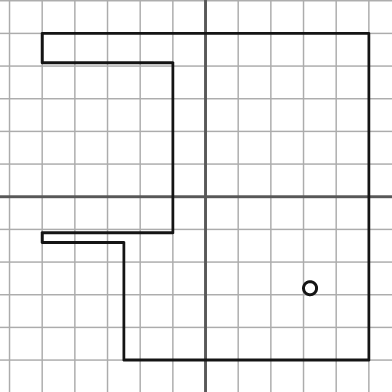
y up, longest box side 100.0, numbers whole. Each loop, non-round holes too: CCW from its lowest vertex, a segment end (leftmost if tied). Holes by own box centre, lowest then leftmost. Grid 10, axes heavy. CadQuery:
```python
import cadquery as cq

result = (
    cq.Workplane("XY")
    .moveTo(-25.0, -50.0)
    .lineTo(50.0, -50.0)
    .lineTo(50.0, 50.0)
    .lineTo(-50.0, 50.0)
    .lineTo(-50.0, 41.0)
    .lineTo(-10.0, 41.0)
    .lineTo(-10.0, -11.0)
    .lineTo(-50.0, -11.0)
    .lineTo(-50.0, -14.0)
    .lineTo(-25.0, -14.0)
    .close()
    .moveTo(32.0, -28.0)
    .circle(2.0)
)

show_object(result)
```